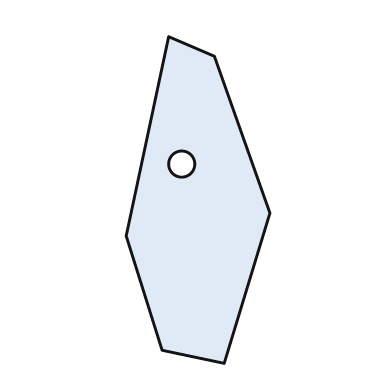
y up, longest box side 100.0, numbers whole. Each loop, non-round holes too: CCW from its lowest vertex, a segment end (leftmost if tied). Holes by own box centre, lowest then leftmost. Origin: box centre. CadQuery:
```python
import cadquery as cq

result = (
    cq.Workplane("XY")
    .moveTo(8.0, -50.0)
    .lineTo(22.0, -4.0)
    .lineTo(5.0, 44.0)
    .lineTo(-9.0, 50.0)
    .lineTo(-22.0, -11.0)
    .lineTo(-11.0, -46.0)
    .close()
    .moveTo(-5.0, 11.0)
    .circle(4.0)
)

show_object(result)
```